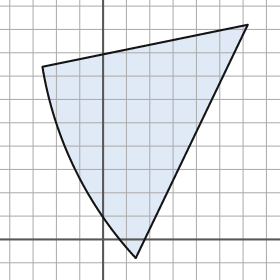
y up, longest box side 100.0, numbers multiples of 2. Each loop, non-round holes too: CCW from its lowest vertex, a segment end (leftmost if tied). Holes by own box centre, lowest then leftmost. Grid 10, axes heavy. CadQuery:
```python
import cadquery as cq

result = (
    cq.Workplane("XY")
    .moveTo(14.0, -8.0)
    .lineTo(62.0, 92.0)
    .lineTo(-26.0, 74.0)
    .threePointArc((-12.0, 30.0), (14.0, -8.0))
    .close()
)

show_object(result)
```